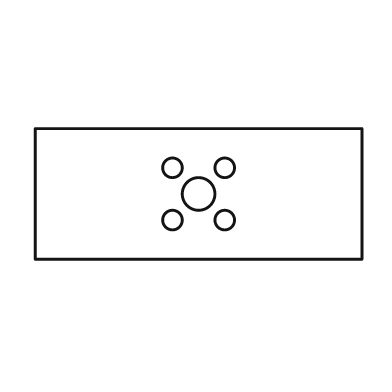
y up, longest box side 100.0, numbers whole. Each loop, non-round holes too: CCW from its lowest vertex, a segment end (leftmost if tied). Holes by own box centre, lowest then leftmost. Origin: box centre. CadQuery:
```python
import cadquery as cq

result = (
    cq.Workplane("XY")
    .moveTo(-50.0, -20.0)
    .lineTo(50.0, -20.0)
    .lineTo(50.0, 20.0)
    .lineTo(-50.0, 20.0)
    .close()
    .moveTo(-8.0, -8.0)
    .circle(3.0)
    .moveTo(8.0, -8.0)
    .circle(3.0)
    .moveTo(0.0, 0.0)
    .circle(5.0)
    .moveTo(-8.0, 8.0)
    .circle(3.0)
    .moveTo(8.0, 8.0)
    .circle(3.0)
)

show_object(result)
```